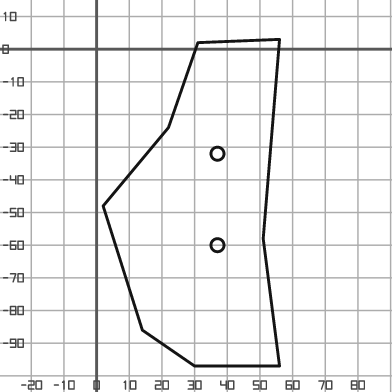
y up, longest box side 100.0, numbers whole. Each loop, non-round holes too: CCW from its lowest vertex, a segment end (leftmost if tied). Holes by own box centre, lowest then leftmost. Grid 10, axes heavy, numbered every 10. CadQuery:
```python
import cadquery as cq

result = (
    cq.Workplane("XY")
    .moveTo(30.0, -97.0)
    .lineTo(56.0, -97.0)
    .lineTo(51.0, -58.0)
    .lineTo(56.0, 3.0)
    .lineTo(31.0, 2.0)
    .lineTo(22.0, -24.0)
    .lineTo(2.0, -48.0)
    .lineTo(14.0, -86.0)
    .close()
    .moveTo(37.0, -60.0)
    .circle(2.0)
    .moveTo(37.0, -32.0)
    .circle(2.0)
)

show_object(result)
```